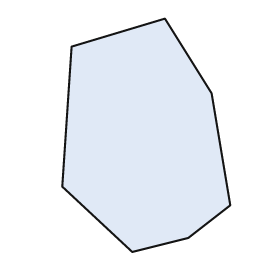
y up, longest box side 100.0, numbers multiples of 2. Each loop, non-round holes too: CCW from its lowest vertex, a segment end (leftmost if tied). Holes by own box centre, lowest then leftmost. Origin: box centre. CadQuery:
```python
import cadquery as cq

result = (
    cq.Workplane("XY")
    .moveTo(-6.0, -50.0)
    .lineTo(18.0, -44.0)
    .lineTo(36.0, -30.0)
    .lineTo(28.0, 18.0)
    .lineTo(8.0, 50.0)
    .lineTo(-32.0, 38.0)
    .lineTo(-36.0, -22.0)
    .close()
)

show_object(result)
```